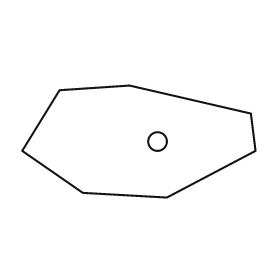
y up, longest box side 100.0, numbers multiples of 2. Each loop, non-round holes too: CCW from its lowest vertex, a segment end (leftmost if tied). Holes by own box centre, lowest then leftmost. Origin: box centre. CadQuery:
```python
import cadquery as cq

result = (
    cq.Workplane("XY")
    .moveTo(12.0, -24.0)
    .lineTo(50.0, -4.0)
    .lineTo(48.0, 12.0)
    .lineTo(-4.0, 24.0)
    .lineTo(-34.0, 22.0)
    .lineTo(-50.0, -4.0)
    .lineTo(-24.0, -22.0)
    .close()
    .moveTo(8.0, 0.0)
    .circle(4.0)
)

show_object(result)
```